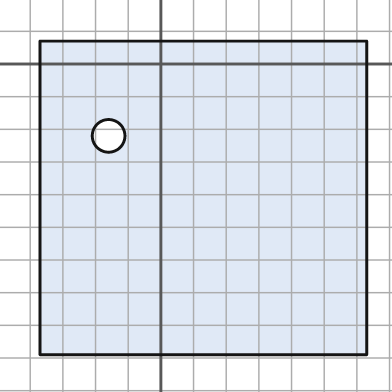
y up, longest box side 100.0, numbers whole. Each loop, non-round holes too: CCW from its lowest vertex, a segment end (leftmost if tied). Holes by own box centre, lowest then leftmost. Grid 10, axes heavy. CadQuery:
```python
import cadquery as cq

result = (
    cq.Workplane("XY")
    .moveTo(-37.0, -89.0)
    .lineTo(63.0, -89.0)
    .lineTo(63.0, 7.0)
    .lineTo(-37.0, 7.0)
    .close()
    .moveTo(-16.0, -22.0)
    .circle(5.0)
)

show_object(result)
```